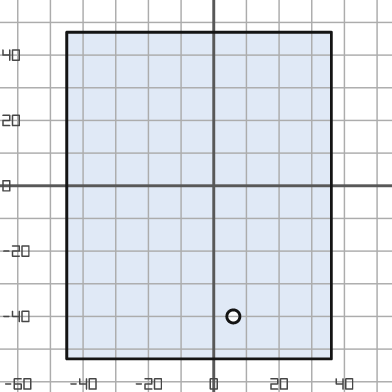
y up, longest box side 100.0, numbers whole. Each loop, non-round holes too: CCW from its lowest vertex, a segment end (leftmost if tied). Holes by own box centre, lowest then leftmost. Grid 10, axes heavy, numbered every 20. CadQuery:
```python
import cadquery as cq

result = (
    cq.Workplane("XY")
    .moveTo(-45.0, -53.0)
    .lineTo(36.0, -53.0)
    .lineTo(36.0, 47.0)
    .lineTo(-45.0, 47.0)
    .close()
    .moveTo(6.0, -40.0)
    .circle(2.0)
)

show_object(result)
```